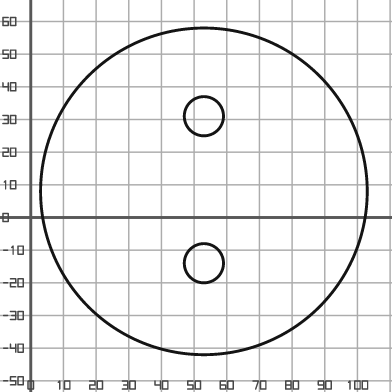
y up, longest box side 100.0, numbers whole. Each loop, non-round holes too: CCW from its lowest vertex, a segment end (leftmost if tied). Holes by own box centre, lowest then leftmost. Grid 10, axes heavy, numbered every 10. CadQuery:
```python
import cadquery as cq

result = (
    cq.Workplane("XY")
    .moveTo(53.0, 8.0)
    .circle(50.0)
    .moveTo(53.0, -14.0)
    .circle(6.0)
    .moveTo(53.0, 31.0)
    .circle(6.0)
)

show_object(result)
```